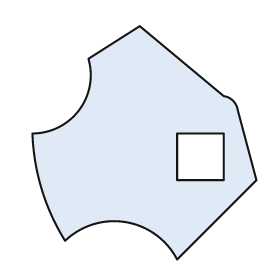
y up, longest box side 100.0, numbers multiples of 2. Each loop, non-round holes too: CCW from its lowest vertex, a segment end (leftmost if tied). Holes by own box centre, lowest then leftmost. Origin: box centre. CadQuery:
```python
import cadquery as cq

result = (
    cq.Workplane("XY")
    .moveTo(14.0, -50.0)
    .lineTo(48.0, -16.0)
    .lineTo(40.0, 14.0)
    .threePointArc((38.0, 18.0), (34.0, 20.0))
    .lineTo(-2.0, 50.0)
    .lineTo(-24.0, 36.0)
    .threePointArc((-28.0, 14.0), (-48.0, 4.0))
    .threePointArc((-44.0, -20.0), (-34.0, -42.0))
    .threePointArc((-8.0, -34.0), (14.0, -50.0))
    .close()
    .moveTo(14.0, -16.0)
    .lineTo(34.0, -16.0)
    .lineTo(34.0, 4.0)
    .lineTo(14.0, 4.0)
    .close()
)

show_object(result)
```